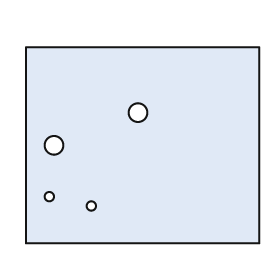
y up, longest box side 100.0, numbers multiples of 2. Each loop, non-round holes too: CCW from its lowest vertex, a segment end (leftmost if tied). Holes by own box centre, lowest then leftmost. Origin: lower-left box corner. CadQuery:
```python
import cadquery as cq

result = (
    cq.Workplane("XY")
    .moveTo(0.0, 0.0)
    .lineTo(100.0, 0.0)
    .lineTo(100.0, 84.0)
    .lineTo(0.0, 84.0)
    .close()
    .moveTo(28.0, 16.0)
    .circle(2.0)
    .moveTo(10.0, 20.0)
    .circle(2.0)
    .moveTo(12.0, 42.0)
    .circle(4.0)
    .moveTo(48.0, 56.0)
    .circle(4.0)
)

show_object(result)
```